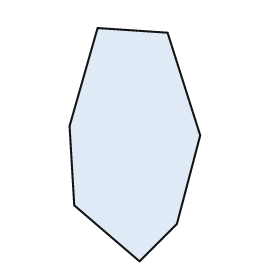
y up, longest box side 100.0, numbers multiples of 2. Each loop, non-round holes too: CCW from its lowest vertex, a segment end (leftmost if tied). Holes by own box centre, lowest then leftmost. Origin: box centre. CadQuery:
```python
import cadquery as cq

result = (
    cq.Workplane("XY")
    .moveTo(2.0, -50.0)
    .lineTo(18.0, -34.0)
    .lineTo(28.0, 4.0)
    .lineTo(14.0, 48.0)
    .lineTo(-16.0, 50.0)
    .lineTo(-28.0, 8.0)
    .lineTo(-26.0, -26.0)
    .close()
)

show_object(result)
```